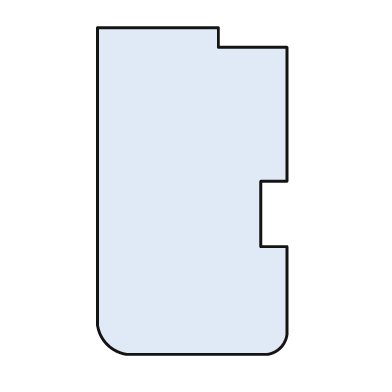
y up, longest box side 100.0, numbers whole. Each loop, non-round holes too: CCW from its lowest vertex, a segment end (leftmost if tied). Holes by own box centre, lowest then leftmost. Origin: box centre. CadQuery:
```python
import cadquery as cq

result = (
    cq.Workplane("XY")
    .moveTo(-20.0, -50.0)
    .lineTo(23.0, -50.0)
    .threePointArc((27.0, -48.0), (29.0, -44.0))
    .lineTo(29.0, -17.0)
    .lineTo(21.0, -17.0)
    .lineTo(21.0, 3.0)
    .lineTo(29.0, 3.0)
    .lineTo(29.0, 44.0)
    .lineTo(8.0, 44.0)
    .lineTo(8.0, 50.0)
    .lineTo(-29.0, 50.0)
    .lineTo(-29.0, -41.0)
    .threePointArc((-26.0, -47.0), (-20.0, -50.0))
    .close()
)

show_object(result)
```